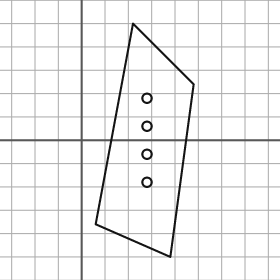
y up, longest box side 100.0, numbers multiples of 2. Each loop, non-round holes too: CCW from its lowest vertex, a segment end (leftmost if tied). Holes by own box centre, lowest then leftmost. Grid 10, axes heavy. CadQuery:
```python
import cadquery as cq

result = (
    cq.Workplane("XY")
    .moveTo(38.0, -50.0)
    .lineTo(48.0, 24.0)
    .lineTo(22.0, 50.0)
    .lineTo(6.0, -36.0)
    .close()
    .moveTo(28.0, -18.0)
    .circle(2.0)
    .moveTo(28.0, -6.0)
    .circle(2.0)
    .moveTo(28.0, 6.0)
    .circle(2.0)
    .moveTo(28.0, 18.0)
    .circle(2.0)
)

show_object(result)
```